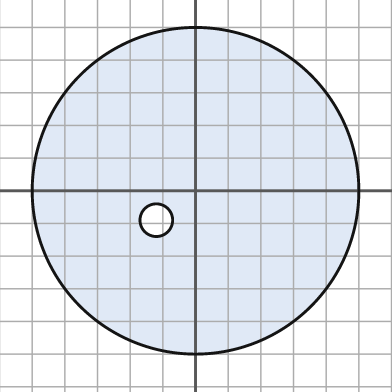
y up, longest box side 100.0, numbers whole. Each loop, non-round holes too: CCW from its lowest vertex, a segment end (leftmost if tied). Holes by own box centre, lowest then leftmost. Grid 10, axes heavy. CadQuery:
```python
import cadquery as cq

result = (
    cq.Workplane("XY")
    .moveTo(0.0, 0.0)
    .circle(50.0)
    .moveTo(-12.0, -9.0)
    .circle(5.0)
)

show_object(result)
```